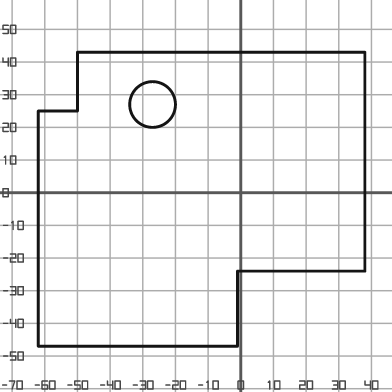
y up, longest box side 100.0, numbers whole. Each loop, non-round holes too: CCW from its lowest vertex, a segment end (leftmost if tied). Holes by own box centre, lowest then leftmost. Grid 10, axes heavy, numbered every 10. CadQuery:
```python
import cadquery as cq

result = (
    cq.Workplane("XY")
    .moveTo(-62.0, -47.0)
    .lineTo(-1.0, -47.0)
    .lineTo(-1.0, -24.0)
    .lineTo(38.0, -24.0)
    .lineTo(38.0, 43.0)
    .lineTo(-50.0, 43.0)
    .lineTo(-50.0, 25.0)
    .lineTo(-62.0, 25.0)
    .close()
    .moveTo(-27.0, 27.0)
    .circle(7.0)
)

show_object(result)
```